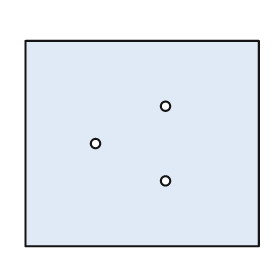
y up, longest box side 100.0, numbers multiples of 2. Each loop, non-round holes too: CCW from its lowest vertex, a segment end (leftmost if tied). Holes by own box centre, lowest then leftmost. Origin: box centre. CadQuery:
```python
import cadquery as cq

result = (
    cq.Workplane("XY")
    .moveTo(-50.0, -44.0)
    .lineTo(50.0, -44.0)
    .lineTo(50.0, 44.0)
    .lineTo(-50.0, 44.0)
    .close()
    .moveTo(10.0, -16.0)
    .circle(2.0)
    .moveTo(-20.0, 0.0)
    .circle(2.0)
    .moveTo(10.0, 16.0)
    .circle(2.0)
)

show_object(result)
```